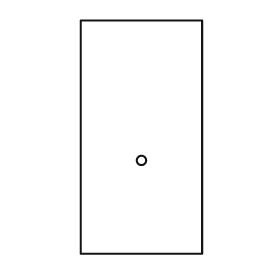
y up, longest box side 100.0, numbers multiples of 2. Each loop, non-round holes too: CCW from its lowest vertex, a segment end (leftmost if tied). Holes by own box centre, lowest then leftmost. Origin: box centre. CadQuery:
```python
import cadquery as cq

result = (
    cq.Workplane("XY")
    .moveTo(-26.0, -50.0)
    .lineTo(26.0, -50.0)
    .lineTo(26.0, 50.0)
    .lineTo(-26.0, 50.0)
    .close()
    .moveTo(0.0, -10.0)
    .circle(2.0)
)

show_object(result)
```